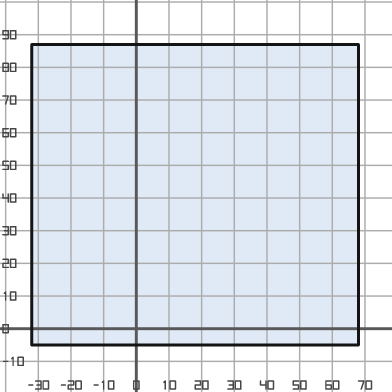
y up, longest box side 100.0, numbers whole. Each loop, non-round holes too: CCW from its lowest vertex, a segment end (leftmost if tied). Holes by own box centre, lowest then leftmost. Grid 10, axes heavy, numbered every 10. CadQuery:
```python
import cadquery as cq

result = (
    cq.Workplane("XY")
    .moveTo(-32.0, -5.0)
    .lineTo(68.0, -5.0)
    .lineTo(68.0, 87.0)
    .lineTo(-32.0, 87.0)
    .close()
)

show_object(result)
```